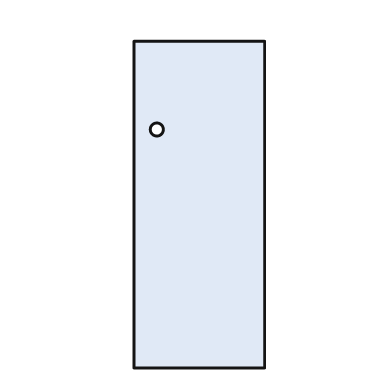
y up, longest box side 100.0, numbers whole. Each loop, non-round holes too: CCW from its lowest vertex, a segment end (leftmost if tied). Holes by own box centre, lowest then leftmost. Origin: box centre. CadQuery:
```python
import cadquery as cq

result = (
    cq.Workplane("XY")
    .moveTo(-20.0, -50.0)
    .lineTo(20.0, -50.0)
    .lineTo(20.0, 50.0)
    .lineTo(-20.0, 50.0)
    .close()
    .moveTo(-13.0, 23.0)
    .circle(2.0)
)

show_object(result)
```